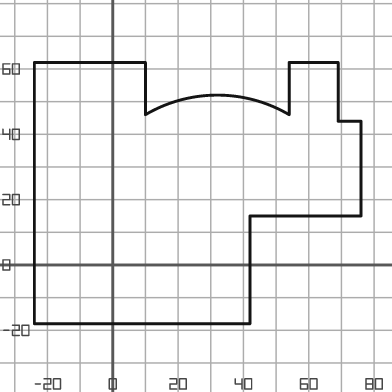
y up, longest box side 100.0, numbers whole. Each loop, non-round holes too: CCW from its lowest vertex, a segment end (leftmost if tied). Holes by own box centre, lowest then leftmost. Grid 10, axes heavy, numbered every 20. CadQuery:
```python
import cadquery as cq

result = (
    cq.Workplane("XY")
    .moveTo(-24.0, -18.0)
    .lineTo(42.0, -18.0)
    .lineTo(42.0, 15.0)
    .lineTo(76.0, 15.0)
    .lineTo(76.0, 44.0)
    .lineTo(69.0, 44.0)
    .lineTo(69.0, 62.0)
    .lineTo(54.0, 62.0)
    .lineTo(54.0, 46.0)
    .threePointArc((32.0, 52.0), (10.0, 46.0))
    .lineTo(10.0, 62.0)
    .lineTo(-24.0, 62.0)
    .close()
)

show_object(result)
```